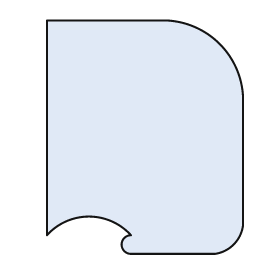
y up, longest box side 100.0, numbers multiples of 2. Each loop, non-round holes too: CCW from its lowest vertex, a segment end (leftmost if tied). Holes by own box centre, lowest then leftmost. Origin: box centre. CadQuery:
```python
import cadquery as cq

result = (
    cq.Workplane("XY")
    .moveTo(-6.0, -50.0)
    .lineTo(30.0, -50.0)
    .threePointArc((38.0, -46.0), (42.0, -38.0))
    .lineTo(42.0, 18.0)
    .threePointArc((32.0, 40.0), (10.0, 50.0))
    .lineTo(-42.0, 50.0)
    .lineTo(-42.0, -42.0)
    .threePointArc((-24.0, -34.0), (-6.0, -42.0))
    .threePointArc((-10.0, -46.0), (-6.0, -50.0))
    .close()
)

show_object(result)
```